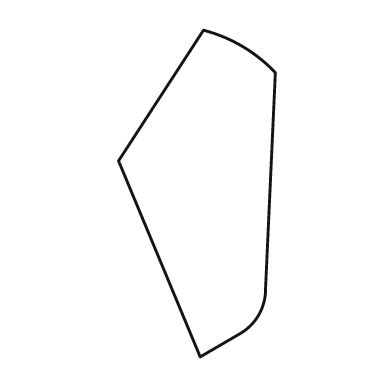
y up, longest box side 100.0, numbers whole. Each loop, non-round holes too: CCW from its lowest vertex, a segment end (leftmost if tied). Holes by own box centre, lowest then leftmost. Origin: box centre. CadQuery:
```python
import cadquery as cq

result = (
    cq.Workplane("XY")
    .moveTo(1.0, -50.0)
    .lineTo(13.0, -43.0)
    .threePointArc((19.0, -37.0), (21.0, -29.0))
    .lineTo(24.0, 37.0)
    .threePointArc((14.0, 45.0), (2.0, 50.0))
    .lineTo(-24.0, 10.0)
    .close()
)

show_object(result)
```